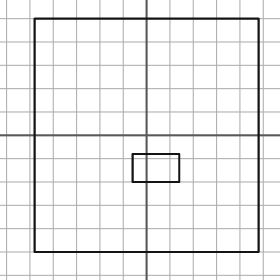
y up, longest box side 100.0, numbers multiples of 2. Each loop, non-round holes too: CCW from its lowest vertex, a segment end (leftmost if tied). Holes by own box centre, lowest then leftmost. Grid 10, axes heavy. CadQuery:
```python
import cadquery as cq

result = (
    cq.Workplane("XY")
    .moveTo(-48.0, -50.0)
    .lineTo(48.0, -50.0)
    .lineTo(48.0, 50.0)
    .lineTo(-48.0, 50.0)
    .close()
    .moveTo(-6.0, -20.0)
    .lineTo(14.0, -20.0)
    .lineTo(14.0, -8.0)
    .lineTo(-6.0, -8.0)
    .close()
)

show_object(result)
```